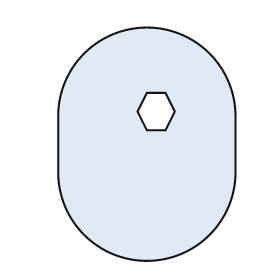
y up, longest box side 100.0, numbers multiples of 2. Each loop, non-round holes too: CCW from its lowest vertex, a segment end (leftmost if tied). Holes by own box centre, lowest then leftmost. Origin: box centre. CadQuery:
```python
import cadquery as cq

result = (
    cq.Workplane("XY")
    .moveTo(-38.0, -12.0)
    .threePointArc((0.0, -50.0), (38.0, -12.0))
    .lineTo(38.0, 12.0)
    .threePointArc((0.0, 50.0), (-38.0, 12.0))
    .close()
    .moveTo(0.0, 6.0)
    .lineTo(8.0, 6.0)
    .lineTo(12.0, 14.0)
    .lineTo(8.0, 22.0)
    .lineTo(0.0, 22.0)
    .lineTo(-4.0, 14.0)
    .close()
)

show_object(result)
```